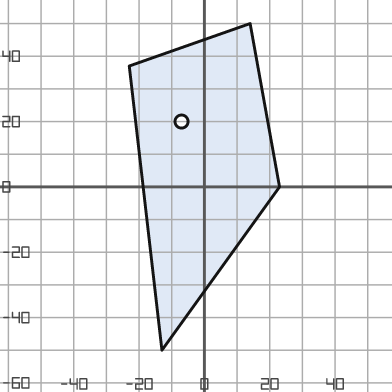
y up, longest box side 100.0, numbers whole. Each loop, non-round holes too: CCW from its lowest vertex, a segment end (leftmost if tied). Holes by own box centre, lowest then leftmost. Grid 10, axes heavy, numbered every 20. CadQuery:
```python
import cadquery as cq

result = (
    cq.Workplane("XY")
    .moveTo(-13.0, -50.0)
    .lineTo(23.0, 0.0)
    .lineTo(14.0, 50.0)
    .lineTo(-23.0, 37.0)
    .close()
    .moveTo(-7.0, 20.0)
    .circle(2.0)
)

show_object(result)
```